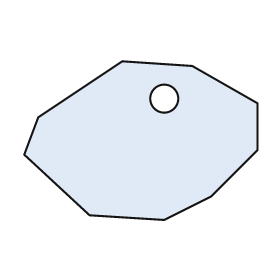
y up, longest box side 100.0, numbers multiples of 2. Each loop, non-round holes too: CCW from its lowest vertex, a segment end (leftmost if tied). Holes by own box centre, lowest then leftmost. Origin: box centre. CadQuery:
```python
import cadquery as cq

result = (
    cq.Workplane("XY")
    .moveTo(10.0, -34.0)
    .lineTo(30.0, -24.0)
    .lineTo(50.0, -4.0)
    .lineTo(50.0, 16.0)
    .lineTo(22.0, 32.0)
    .lineTo(-8.0, 34.0)
    .lineTo(-44.0, 10.0)
    .lineTo(-50.0, -6.0)
    .lineTo(-22.0, -32.0)
    .close()
    .moveTo(10.0, 18.0)
    .circle(6.0)
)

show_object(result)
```